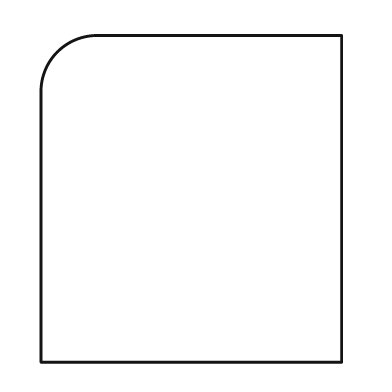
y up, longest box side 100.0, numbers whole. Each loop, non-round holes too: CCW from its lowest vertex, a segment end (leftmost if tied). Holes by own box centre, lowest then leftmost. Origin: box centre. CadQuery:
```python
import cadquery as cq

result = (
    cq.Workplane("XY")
    .moveTo(-46.0, -50.0)
    .lineTo(46.0, -50.0)
    .lineTo(46.0, 50.0)
    .lineTo(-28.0, 50.0)
    .threePointArc((-41.0, 45.0), (-46.0, 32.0))
    .close()
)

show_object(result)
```